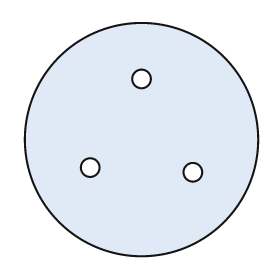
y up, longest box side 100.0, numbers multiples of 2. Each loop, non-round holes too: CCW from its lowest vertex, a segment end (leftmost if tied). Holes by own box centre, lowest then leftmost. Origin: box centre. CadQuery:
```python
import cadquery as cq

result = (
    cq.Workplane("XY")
    .moveTo(0.0, 0.0)
    .circle(50.0)
    .moveTo(22.0, -14.0)
    .circle(4.0)
    .moveTo(-22.0, -12.0)
    .circle(4.0)
    .moveTo(0.0, 26.0)
    .circle(4.0)
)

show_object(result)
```